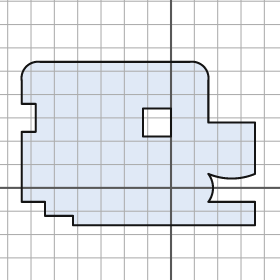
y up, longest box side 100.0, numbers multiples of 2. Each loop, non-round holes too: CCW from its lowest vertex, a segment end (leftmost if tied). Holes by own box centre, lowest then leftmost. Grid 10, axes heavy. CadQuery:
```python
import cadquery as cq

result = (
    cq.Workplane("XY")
    .moveTo(-42.0, -16.0)
    .lineTo(36.0, -16.0)
    .lineTo(36.0, -6.0)
    .lineTo(16.0, -6.0)
    .threePointArc((18.0, 0.0), (16.0, 6.0))
    .threePointArc((26.0, 4.0), (36.0, 6.0))
    .lineTo(36.0, 28.0)
    .lineTo(16.0, 28.0)
    .lineTo(16.0, 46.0)
    .threePointArc((14.0, 52.0), (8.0, 54.0))
    .lineTo(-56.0, 54.0)
    .threePointArc((-62.0, 52.0), (-64.0, 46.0))
    .lineTo(-64.0, 36.0)
    .lineTo(-58.0, 36.0)
    .lineTo(-58.0, 24.0)
    .lineTo(-64.0, 24.0)
    .lineTo(-64.0, -6.0)
    .lineTo(-54.0, -6.0)
    .lineTo(-54.0, -12.0)
    .lineTo(-42.0, -12.0)
    .close()
    .moveTo(-12.0, 22.0)
    .lineTo(0.0, 22.0)
    .lineTo(0.0, 34.0)
    .lineTo(-12.0, 34.0)
    .close()
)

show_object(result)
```